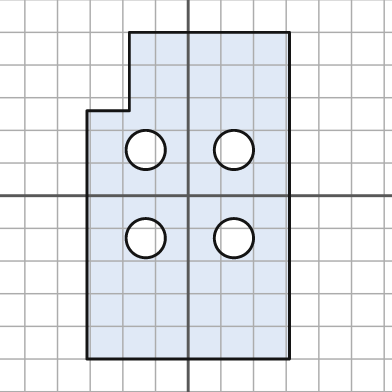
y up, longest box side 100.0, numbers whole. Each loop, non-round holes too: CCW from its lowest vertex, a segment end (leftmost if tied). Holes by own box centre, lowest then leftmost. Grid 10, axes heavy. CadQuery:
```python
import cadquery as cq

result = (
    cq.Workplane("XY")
    .moveTo(-31.0, -50.0)
    .lineTo(31.0, -50.0)
    .lineTo(31.0, 50.0)
    .lineTo(-18.0, 50.0)
    .lineTo(-18.0, 26.0)
    .lineTo(-31.0, 26.0)
    .close()
    .moveTo(-13.0, -13.0)
    .circle(6.0)
    .moveTo(14.0, -13.0)
    .circle(6.0)
    .moveTo(-13.0, 14.0)
    .circle(6.0)
    .moveTo(14.0, 14.0)
    .circle(6.0)
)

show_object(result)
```